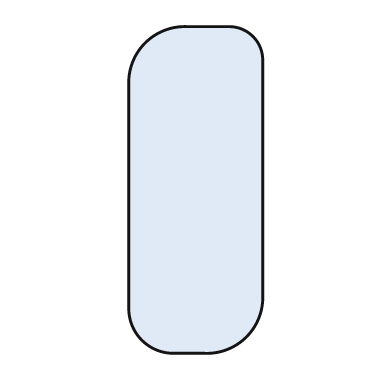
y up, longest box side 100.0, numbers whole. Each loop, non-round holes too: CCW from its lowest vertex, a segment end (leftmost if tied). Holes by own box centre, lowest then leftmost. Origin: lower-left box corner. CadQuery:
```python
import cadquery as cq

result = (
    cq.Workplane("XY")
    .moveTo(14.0, 0.0)
    .lineTo(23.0, 0.0)
    .threePointArc((36.0, 5.0), (41.0, 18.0))
    .lineTo(41.0, 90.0)
    .threePointArc((38.0, 97.0), (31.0, 100.0))
    .lineTo(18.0, 100.0)
    .threePointArc((5.0, 95.0), (0.0, 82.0))
    .lineTo(0.0, 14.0)
    .threePointArc((4.0, 4.0), (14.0, 0.0))
    .close()
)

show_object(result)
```